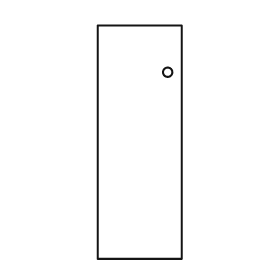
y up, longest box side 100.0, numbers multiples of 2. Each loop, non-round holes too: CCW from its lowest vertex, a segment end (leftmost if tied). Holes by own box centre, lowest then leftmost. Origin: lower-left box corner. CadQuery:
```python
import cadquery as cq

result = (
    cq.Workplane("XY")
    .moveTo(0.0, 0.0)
    .lineTo(36.0, 0.0)
    .lineTo(36.0, 100.0)
    .lineTo(0.0, 100.0)
    .close()
    .moveTo(30.0, 80.0)
    .circle(2.0)
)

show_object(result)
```